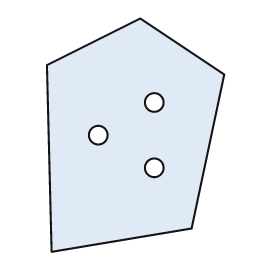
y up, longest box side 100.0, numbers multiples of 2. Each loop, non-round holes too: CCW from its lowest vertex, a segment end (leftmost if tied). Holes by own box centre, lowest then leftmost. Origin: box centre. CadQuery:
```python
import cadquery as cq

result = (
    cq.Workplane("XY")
    .moveTo(-36.0, -50.0)
    .lineTo(24.0, -40.0)
    .lineTo(38.0, 26.0)
    .lineTo(2.0, 50.0)
    .lineTo(-38.0, 30.0)
    .close()
    .moveTo(8.0, -14.0)
    .circle(4.0)
    .moveTo(-16.0, 0.0)
    .circle(4.0)
    .moveTo(8.0, 14.0)
    .circle(4.0)
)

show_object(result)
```